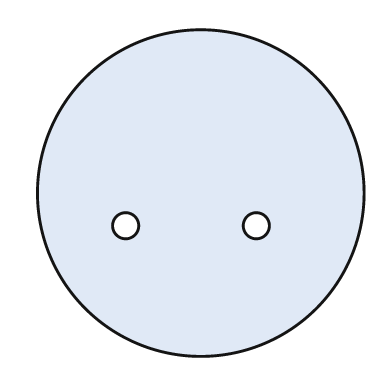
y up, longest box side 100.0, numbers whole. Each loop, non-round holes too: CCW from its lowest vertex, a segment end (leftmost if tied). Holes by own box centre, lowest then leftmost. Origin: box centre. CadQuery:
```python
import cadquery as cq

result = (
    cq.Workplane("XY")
    .moveTo(0.0, 0.0)
    .circle(50.0)
    .moveTo(-23.0, -10.0)
    .circle(4.0)
    .moveTo(17.0, -10.0)
    .circle(4.0)
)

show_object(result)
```